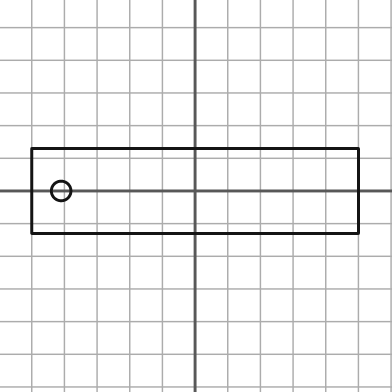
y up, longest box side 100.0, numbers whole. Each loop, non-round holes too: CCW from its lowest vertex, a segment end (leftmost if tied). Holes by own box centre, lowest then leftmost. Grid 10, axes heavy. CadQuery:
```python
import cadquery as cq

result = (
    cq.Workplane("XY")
    .moveTo(-50.0, -13.0)
    .lineTo(50.0, -13.0)
    .lineTo(50.0, 13.0)
    .lineTo(-50.0, 13.0)
    .close()
    .moveTo(-41.0, 0.0)
    .circle(3.0)
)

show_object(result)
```